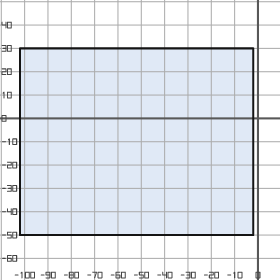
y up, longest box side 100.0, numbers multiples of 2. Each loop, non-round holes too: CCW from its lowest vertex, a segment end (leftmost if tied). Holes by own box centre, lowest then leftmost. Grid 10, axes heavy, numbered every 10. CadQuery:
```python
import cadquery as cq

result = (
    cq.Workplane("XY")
    .moveTo(-102.0, -50.0)
    .lineTo(-2.0, -50.0)
    .lineTo(-2.0, 30.0)
    .lineTo(-102.0, 30.0)
    .close()
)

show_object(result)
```